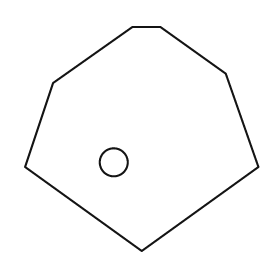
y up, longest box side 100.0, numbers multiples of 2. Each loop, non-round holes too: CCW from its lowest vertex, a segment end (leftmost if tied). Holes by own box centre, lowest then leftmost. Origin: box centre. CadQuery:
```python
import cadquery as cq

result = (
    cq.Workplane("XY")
    .moveTo(0.0, -48.0)
    .lineTo(50.0, -12.0)
    .lineTo(36.0, 28.0)
    .lineTo(8.0, 48.0)
    .lineTo(-4.0, 48.0)
    .lineTo(-38.0, 24.0)
    .lineTo(-50.0, -12.0)
    .close()
    .moveTo(-12.0, -10.0)
    .circle(6.0)
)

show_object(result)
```